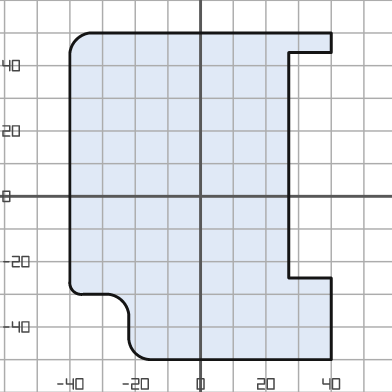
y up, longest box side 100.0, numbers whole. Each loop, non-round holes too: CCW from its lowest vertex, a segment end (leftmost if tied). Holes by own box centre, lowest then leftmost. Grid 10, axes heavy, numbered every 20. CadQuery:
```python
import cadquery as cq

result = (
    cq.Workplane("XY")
    .moveTo(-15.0, -50.0)
    .lineTo(40.0, -50.0)
    .lineTo(40.0, -25.0)
    .lineTo(27.0, -25.0)
    .lineTo(27.0, 44.0)
    .lineTo(40.0, 44.0)
    .lineTo(40.0, 50.0)
    .lineTo(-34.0, 50.0)
    .threePointArc((-38.0, 48.0), (-40.0, 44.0))
    .lineTo(-40.0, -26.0)
    .threePointArc((-39.0, -29.0), (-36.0, -30.0))
    .lineTo(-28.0, -30.0)
    .threePointArc((-24.0, -32.0), (-22.0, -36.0))
    .lineTo(-22.0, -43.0)
    .threePointArc((-20.0, -48.0), (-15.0, -50.0))
    .close()
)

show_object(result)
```